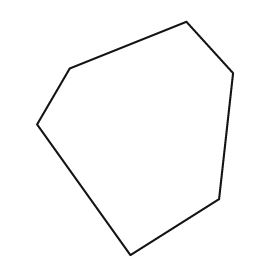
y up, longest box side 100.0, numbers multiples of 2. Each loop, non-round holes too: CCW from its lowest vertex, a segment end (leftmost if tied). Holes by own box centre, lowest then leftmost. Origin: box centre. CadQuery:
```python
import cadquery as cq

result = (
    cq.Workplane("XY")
    .moveTo(-2.0, -50.0)
    .lineTo(36.0, -26.0)
    .lineTo(42.0, 28.0)
    .lineTo(22.0, 50.0)
    .lineTo(-28.0, 30.0)
    .lineTo(-42.0, 6.0)
    .close()
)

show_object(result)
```